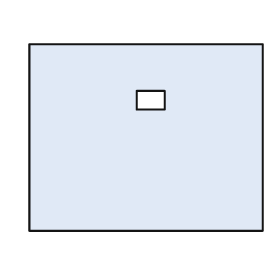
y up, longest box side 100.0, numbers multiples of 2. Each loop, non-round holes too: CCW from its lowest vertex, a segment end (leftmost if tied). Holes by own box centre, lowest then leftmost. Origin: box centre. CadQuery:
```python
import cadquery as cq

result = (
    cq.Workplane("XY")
    .moveTo(-50.0, -40.0)
    .lineTo(50.0, -40.0)
    .lineTo(50.0, 40.0)
    .lineTo(-50.0, 40.0)
    .close()
    .moveTo(-4.0, 12.0)
    .lineTo(8.0, 12.0)
    .lineTo(8.0, 20.0)
    .lineTo(-4.0, 20.0)
    .close()
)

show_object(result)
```